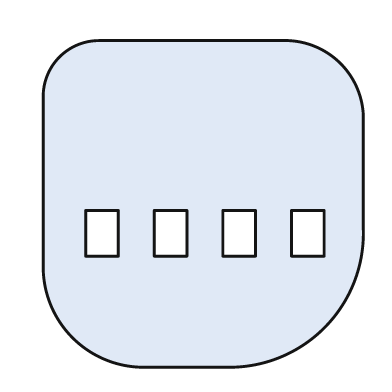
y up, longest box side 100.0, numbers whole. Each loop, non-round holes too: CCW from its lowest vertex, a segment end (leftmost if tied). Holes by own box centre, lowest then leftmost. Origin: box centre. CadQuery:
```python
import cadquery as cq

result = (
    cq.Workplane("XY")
    .moveTo(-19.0, -50.0)
    .lineTo(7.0, -50.0)
    .threePointArc((37.0, -38.0), (49.0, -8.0))
    .lineTo(49.0, 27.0)
    .threePointArc((42.0, 43.0), (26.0, 50.0))
    .lineTo(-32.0, 50.0)
    .threePointArc((-44.0, 45.0), (-49.0, 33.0))
    .lineTo(-49.0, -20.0)
    .threePointArc((-40.0, -41.0), (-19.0, -50.0))
    .close()
    .moveTo(-36.0, -16.0)
    .lineTo(-26.0, -16.0)
    .lineTo(-26.0, -2.0)
    .lineTo(-36.0, -2.0)
    .close()
    .moveTo(-15.0, -16.0)
    .lineTo(-5.0, -16.0)
    .lineTo(-5.0, -2.0)
    .lineTo(-15.0, -2.0)
    .close()
    .moveTo(6.0, -16.0)
    .lineTo(16.0, -16.0)
    .lineTo(16.0, -2.0)
    .lineTo(6.0, -2.0)
    .close()
    .moveTo(27.0, -16.0)
    .lineTo(37.0, -16.0)
    .lineTo(37.0, -2.0)
    .lineTo(27.0, -2.0)
    .close()
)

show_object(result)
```